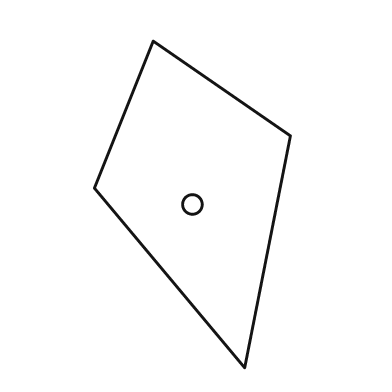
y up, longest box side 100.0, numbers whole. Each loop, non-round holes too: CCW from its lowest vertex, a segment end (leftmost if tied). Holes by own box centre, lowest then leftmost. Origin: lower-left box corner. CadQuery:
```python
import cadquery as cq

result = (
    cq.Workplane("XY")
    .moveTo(46.0, 0.0)
    .lineTo(60.0, 71.0)
    .lineTo(18.0, 100.0)
    .lineTo(0.0, 55.0)
    .close()
    .moveTo(30.0, 50.0)
    .circle(3.0)
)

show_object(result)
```